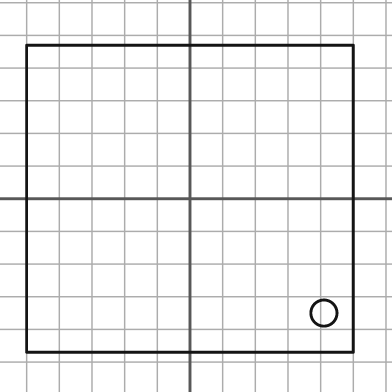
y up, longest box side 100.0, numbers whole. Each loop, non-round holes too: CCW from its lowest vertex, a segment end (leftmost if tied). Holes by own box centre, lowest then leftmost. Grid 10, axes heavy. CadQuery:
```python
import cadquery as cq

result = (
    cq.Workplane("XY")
    .moveTo(-50.0, -47.0)
    .lineTo(50.0, -47.0)
    .lineTo(50.0, 47.0)
    .lineTo(-50.0, 47.0)
    .close()
    .moveTo(41.0, -35.0)
    .circle(4.0)
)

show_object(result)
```